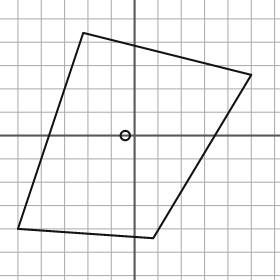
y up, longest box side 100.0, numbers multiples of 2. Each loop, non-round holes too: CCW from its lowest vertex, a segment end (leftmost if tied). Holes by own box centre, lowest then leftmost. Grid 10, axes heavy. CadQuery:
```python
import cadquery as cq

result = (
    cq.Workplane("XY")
    .moveTo(8.0, -44.0)
    .lineTo(50.0, 26.0)
    .lineTo(-22.0, 44.0)
    .lineTo(-50.0, -40.0)
    .close()
    .moveTo(-4.0, 0.0)
    .circle(2.0)
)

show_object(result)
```